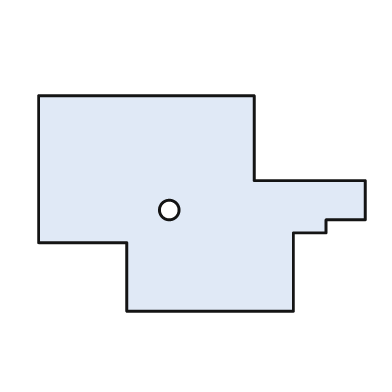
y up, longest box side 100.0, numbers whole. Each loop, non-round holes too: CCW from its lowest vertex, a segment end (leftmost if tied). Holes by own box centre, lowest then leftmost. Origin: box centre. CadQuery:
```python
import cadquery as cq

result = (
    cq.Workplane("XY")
    .moveTo(-23.0, -33.0)
    .lineTo(28.0, -33.0)
    .lineTo(28.0, -9.0)
    .lineTo(38.0, -9.0)
    .lineTo(38.0, -5.0)
    .lineTo(50.0, -5.0)
    .lineTo(50.0, 7.0)
    .lineTo(16.0, 7.0)
    .lineTo(16.0, 33.0)
    .lineTo(-50.0, 33.0)
    .lineTo(-50.0, -12.0)
    .lineTo(-23.0, -12.0)
    .close()
    .moveTo(-10.0, -2.0)
    .circle(3.0)
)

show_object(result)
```